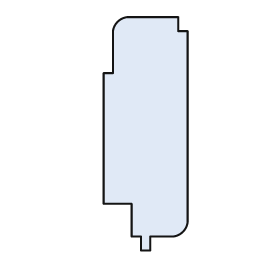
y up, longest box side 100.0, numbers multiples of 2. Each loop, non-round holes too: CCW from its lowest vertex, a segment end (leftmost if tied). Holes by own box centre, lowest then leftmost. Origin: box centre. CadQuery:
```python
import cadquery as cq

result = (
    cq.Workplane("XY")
    .moveTo(-2.0, -50.0)
    .lineTo(2.0, -50.0)
    .lineTo(2.0, -44.0)
    .lineTo(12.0, -44.0)
    .threePointArc((16.0, -42.0), (18.0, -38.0))
    .lineTo(18.0, 44.0)
    .lineTo(14.0, 44.0)
    .lineTo(14.0, 50.0)
    .lineTo(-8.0, 50.0)
    .threePointArc((-12.0, 48.0), (-14.0, 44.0))
    .lineTo(-14.0, 26.0)
    .lineTo(-18.0, 26.0)
    .lineTo(-18.0, -30.0)
    .lineTo(-6.0, -30.0)
    .lineTo(-6.0, -44.0)
    .lineTo(-2.0, -44.0)
    .close()
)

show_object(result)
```